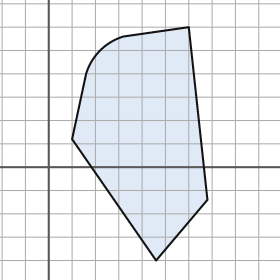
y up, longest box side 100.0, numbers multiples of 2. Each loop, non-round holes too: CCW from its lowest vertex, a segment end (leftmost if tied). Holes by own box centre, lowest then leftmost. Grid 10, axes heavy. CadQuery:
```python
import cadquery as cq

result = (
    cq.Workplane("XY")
    .moveTo(46.0, -40.0)
    .lineTo(68.0, -14.0)
    .lineTo(60.0, 60.0)
    .lineTo(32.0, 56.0)
    .threePointArc((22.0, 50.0), (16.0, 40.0))
    .lineTo(10.0, 12.0)
    .close()
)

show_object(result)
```